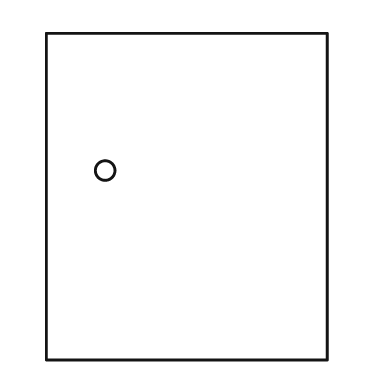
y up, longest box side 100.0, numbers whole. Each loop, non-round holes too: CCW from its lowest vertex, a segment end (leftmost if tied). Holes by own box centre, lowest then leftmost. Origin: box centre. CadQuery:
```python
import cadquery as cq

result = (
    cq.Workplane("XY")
    .moveTo(-43.0, -50.0)
    .lineTo(43.0, -50.0)
    .lineTo(43.0, 50.0)
    .lineTo(-43.0, 50.0)
    .close()
    .moveTo(-25.0, 8.0)
    .circle(3.0)
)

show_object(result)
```